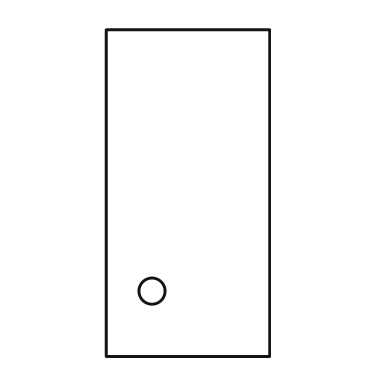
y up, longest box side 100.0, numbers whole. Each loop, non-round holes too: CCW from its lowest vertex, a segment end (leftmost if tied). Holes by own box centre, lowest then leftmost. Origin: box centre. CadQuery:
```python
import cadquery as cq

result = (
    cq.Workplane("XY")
    .moveTo(-25.0, -50.0)
    .lineTo(25.0, -50.0)
    .lineTo(25.0, 50.0)
    .lineTo(-25.0, 50.0)
    .close()
    .moveTo(-11.0, -30.0)
    .circle(4.0)
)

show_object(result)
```